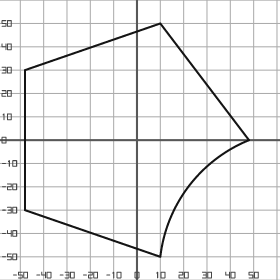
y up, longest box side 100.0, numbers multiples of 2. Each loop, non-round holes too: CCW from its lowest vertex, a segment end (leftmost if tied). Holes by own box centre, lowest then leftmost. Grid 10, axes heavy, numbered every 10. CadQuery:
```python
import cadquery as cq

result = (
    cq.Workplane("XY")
    .moveTo(10.0, -50.0)
    .threePointArc((22.0, -20.0), (48.0, 0.0))
    .lineTo(10.0, 50.0)
    .lineTo(-48.0, 30.0)
    .lineTo(-48.0, -30.0)
    .close()
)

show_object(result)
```